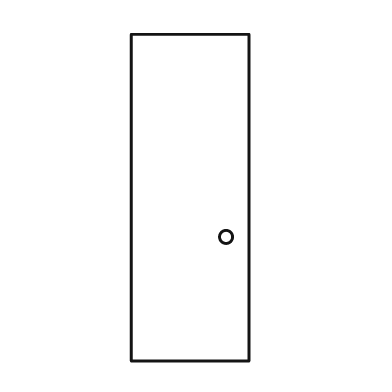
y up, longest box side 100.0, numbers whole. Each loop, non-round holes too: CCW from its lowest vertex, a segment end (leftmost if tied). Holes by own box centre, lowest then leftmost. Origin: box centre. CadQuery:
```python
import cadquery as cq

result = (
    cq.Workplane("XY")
    .moveTo(-18.0, -50.0)
    .lineTo(18.0, -50.0)
    .lineTo(18.0, 50.0)
    .lineTo(-18.0, 50.0)
    .close()
    .moveTo(11.0, -12.0)
    .circle(2.0)
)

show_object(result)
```